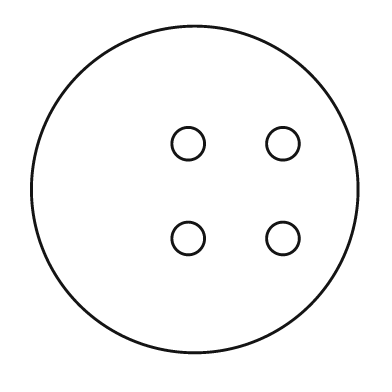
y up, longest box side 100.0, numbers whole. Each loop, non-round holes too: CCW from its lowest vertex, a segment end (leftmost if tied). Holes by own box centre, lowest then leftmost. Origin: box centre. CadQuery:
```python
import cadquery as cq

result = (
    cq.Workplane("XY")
    .moveTo(0.0, 0.0)
    .circle(50.0)
    .moveTo(-2.0, -15.0)
    .circle(5.0)
    .moveTo(27.0, -15.0)
    .circle(5.0)
    .moveTo(-2.0, 14.0)
    .circle(5.0)
    .moveTo(27.0, 14.0)
    .circle(5.0)
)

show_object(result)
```